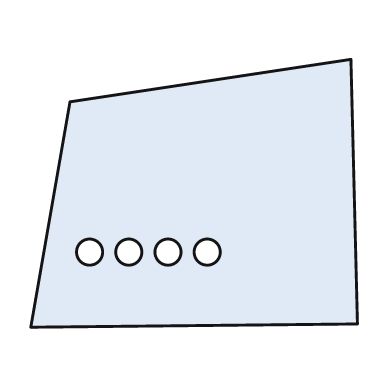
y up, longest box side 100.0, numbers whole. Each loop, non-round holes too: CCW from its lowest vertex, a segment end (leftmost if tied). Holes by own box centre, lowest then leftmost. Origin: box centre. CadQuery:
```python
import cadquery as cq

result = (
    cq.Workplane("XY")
    .moveTo(-50.0, -41.0)
    .lineTo(50.0, -40.0)
    .lineTo(48.0, 41.0)
    .lineTo(-38.0, 28.0)
    .close()
    .moveTo(-32.0, -18.0)
    .circle(4.0)
    .moveTo(-20.0, -18.0)
    .circle(4.0)
    .moveTo(-8.0, -18.0)
    .circle(4.0)
    .moveTo(4.0, -18.0)
    .circle(4.0)
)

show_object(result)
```